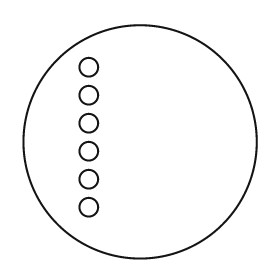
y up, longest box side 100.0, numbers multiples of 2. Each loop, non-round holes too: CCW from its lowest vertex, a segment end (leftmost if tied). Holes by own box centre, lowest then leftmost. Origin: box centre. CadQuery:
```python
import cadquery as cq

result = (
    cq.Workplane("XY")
    .moveTo(0.0, 0.0)
    .circle(50.0)
    .moveTo(-22.0, -28.0)
    .circle(4.0)
    .moveTo(-22.0, -16.0)
    .circle(4.0)
    .moveTo(-22.0, -4.0)
    .circle(4.0)
    .moveTo(-22.0, 8.0)
    .circle(4.0)
    .moveTo(-22.0, 20.0)
    .circle(4.0)
    .moveTo(-22.0, 32.0)
    .circle(4.0)
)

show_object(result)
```